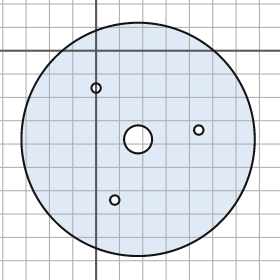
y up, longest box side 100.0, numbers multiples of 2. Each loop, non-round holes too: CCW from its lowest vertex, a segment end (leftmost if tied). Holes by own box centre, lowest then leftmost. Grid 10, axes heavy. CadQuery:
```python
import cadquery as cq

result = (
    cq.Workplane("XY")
    .moveTo(18.0, -38.0)
    .circle(50.0)
    .moveTo(8.0, -64.0)
    .circle(2.0)
    .moveTo(18.0, -38.0)
    .circle(6.0)
    .moveTo(44.0, -34.0)
    .circle(2.0)
    .moveTo(0.0, -16.0)
    .circle(2.0)
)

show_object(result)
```